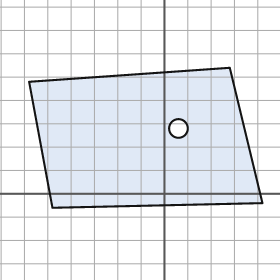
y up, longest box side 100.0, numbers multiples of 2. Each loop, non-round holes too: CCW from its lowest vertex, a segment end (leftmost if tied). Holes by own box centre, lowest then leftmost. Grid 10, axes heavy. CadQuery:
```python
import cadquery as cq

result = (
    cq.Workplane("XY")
    .moveTo(-48.0, -6.0)
    .lineTo(42.0, -4.0)
    .lineTo(28.0, 54.0)
    .lineTo(-58.0, 48.0)
    .close()
    .moveTo(6.0, 28.0)
    .circle(4.0)
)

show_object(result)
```